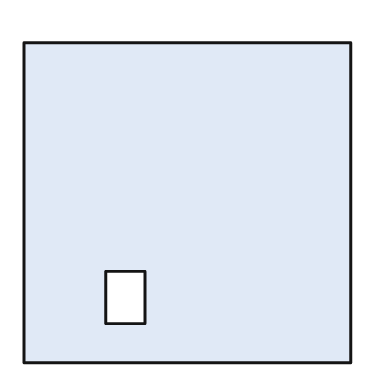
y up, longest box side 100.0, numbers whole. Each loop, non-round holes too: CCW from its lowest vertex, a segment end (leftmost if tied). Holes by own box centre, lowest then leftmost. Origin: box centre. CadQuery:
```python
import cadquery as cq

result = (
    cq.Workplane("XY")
    .moveTo(-50.0, -49.0)
    .lineTo(50.0, -49.0)
    .lineTo(50.0, 49.0)
    .lineTo(-50.0, 49.0)
    .close()
    .moveTo(-25.0, -37.0)
    .lineTo(-13.0, -37.0)
    .lineTo(-13.0, -21.0)
    .lineTo(-25.0, -21.0)
    .close()
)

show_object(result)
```